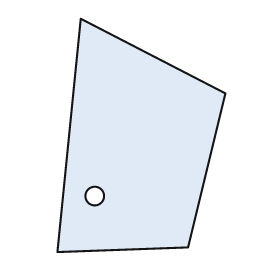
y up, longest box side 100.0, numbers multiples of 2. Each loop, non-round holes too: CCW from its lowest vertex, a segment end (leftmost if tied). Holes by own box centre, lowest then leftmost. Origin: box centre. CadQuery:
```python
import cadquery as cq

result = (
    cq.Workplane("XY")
    .moveTo(-36.0, -50.0)
    .lineTo(20.0, -48.0)
    .lineTo(36.0, 18.0)
    .lineTo(-26.0, 50.0)
    .close()
    .moveTo(-20.0, -26.0)
    .circle(4.0)
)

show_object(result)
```